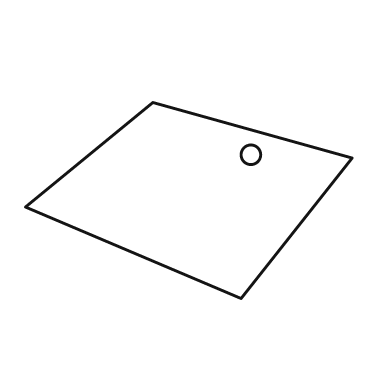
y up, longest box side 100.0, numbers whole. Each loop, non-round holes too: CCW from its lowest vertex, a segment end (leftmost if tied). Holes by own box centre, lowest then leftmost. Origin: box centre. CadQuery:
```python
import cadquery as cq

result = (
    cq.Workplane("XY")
    .moveTo(16.0, -30.0)
    .lineTo(50.0, 13.0)
    .lineTo(-11.0, 30.0)
    .lineTo(-50.0, -2.0)
    .close()
    .moveTo(19.0, 14.0)
    .circle(3.0)
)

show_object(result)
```